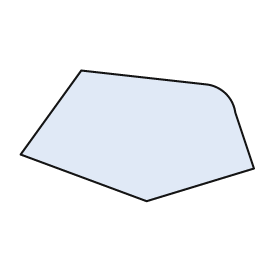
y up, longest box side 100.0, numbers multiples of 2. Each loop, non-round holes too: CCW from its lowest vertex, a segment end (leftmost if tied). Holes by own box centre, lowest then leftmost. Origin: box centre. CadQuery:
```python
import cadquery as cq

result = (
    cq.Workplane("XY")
    .moveTo(4.0, -28.0)
    .lineTo(50.0, -14.0)
    .lineTo(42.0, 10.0)
    .threePointArc((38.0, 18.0), (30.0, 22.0))
    .lineTo(-24.0, 28.0)
    .lineTo(-50.0, -8.0)
    .close()
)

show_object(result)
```